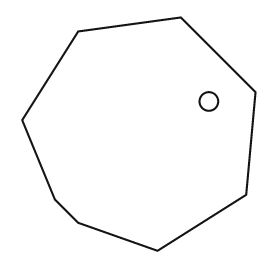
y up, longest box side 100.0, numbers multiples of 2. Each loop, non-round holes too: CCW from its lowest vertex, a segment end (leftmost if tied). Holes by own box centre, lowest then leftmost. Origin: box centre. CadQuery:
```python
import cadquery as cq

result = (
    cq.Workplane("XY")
    .moveTo(8.0, -50.0)
    .lineTo(46.0, -26.0)
    .lineTo(50.0, 18.0)
    .lineTo(18.0, 50.0)
    .lineTo(-26.0, 44.0)
    .lineTo(-50.0, 6.0)
    .lineTo(-36.0, -28.0)
    .lineTo(-26.0, -38.0)
    .close()
    .moveTo(30.0, 14.0)
    .circle(4.0)
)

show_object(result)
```